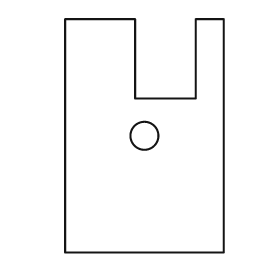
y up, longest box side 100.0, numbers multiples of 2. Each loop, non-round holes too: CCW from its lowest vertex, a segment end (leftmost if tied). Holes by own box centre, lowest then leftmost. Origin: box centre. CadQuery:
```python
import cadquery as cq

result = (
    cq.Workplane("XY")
    .moveTo(-34.0, -50.0)
    .lineTo(34.0, -50.0)
    .lineTo(34.0, 50.0)
    .lineTo(22.0, 50.0)
    .lineTo(22.0, 16.0)
    .lineTo(-4.0, 16.0)
    .lineTo(-4.0, 50.0)
    .lineTo(-34.0, 50.0)
    .close()
    .moveTo(0.0, 0.0)
    .circle(6.0)
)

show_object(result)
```